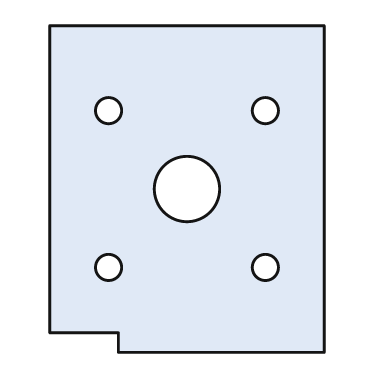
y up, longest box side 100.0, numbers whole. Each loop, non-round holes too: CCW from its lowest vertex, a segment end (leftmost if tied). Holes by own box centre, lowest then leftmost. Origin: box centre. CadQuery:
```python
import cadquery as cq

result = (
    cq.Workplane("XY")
    .moveTo(-21.0, -50.0)
    .lineTo(42.0, -50.0)
    .lineTo(42.0, 50.0)
    .lineTo(-42.0, 50.0)
    .lineTo(-42.0, -44.0)
    .lineTo(-21.0, -44.0)
    .close()
    .moveTo(-24.0, -24.0)
    .circle(4.0)
    .moveTo(24.0, -24.0)
    .circle(4.0)
    .moveTo(0.0, 0.0)
    .circle(10.0)
    .moveTo(-24.0, 24.0)
    .circle(4.0)
    .moveTo(24.0, 24.0)
    .circle(4.0)
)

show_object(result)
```